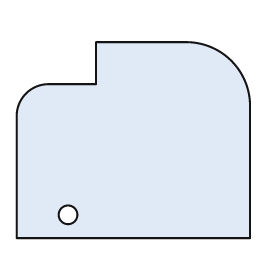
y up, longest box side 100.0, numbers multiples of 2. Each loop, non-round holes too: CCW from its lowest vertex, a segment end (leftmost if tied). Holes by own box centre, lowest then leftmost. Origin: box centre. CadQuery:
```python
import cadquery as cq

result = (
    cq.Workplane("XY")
    .moveTo(-50.0, -42.0)
    .lineTo(50.0, -42.0)
    .lineTo(50.0, 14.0)
    .threePointArc((42.0, 34.0), (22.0, 42.0))
    .lineTo(-16.0, 42.0)
    .lineTo(-16.0, 24.0)
    .lineTo(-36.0, 24.0)
    .threePointArc((-46.0, 20.0), (-50.0, 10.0))
    .close()
    .moveTo(-28.0, -32.0)
    .circle(4.0)
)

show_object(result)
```